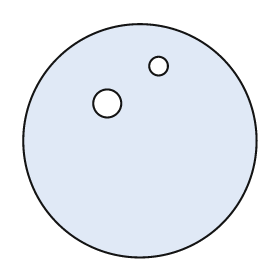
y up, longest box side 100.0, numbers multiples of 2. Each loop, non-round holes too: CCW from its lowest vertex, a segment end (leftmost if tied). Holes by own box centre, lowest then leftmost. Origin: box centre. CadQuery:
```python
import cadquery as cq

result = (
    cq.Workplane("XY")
    .moveTo(0.0, 0.0)
    .circle(50.0)
    .moveTo(-14.0, 16.0)
    .circle(6.0)
    .moveTo(8.0, 32.0)
    .circle(4.0)
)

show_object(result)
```